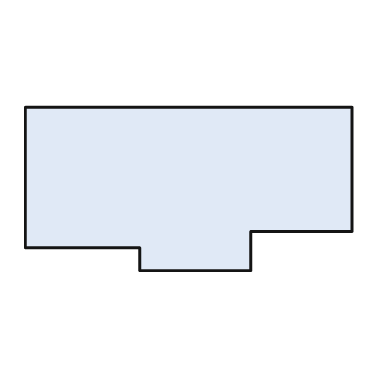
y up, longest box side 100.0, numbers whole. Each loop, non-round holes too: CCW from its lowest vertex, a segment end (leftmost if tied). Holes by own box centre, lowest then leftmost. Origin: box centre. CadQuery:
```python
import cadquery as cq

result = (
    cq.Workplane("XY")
    .moveTo(-15.0, -25.0)
    .lineTo(19.0, -25.0)
    .lineTo(19.0, -13.0)
    .lineTo(50.0, -13.0)
    .lineTo(50.0, 25.0)
    .lineTo(-50.0, 25.0)
    .lineTo(-50.0, -18.0)
    .lineTo(-15.0, -18.0)
    .close()
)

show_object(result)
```